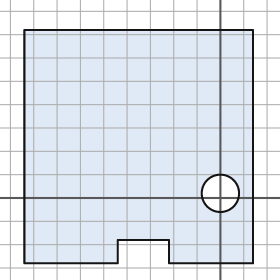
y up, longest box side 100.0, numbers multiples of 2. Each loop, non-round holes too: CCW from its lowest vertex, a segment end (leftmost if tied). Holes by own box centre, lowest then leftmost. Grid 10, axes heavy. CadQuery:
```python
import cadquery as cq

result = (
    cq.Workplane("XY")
    .moveTo(-84.0, -28.0)
    .lineTo(-44.0, -28.0)
    .lineTo(-44.0, -18.0)
    .lineTo(-22.0, -18.0)
    .lineTo(-22.0, -28.0)
    .lineTo(14.0, -28.0)
    .lineTo(14.0, 72.0)
    .lineTo(-84.0, 72.0)
    .close()
    .moveTo(0.0, 2.0)
    .circle(8.0)
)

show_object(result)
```